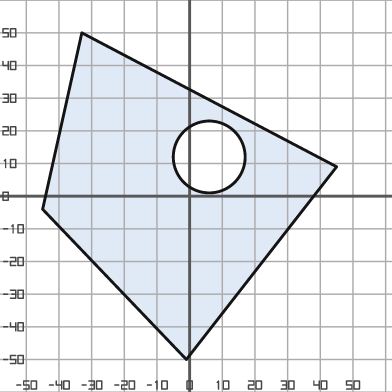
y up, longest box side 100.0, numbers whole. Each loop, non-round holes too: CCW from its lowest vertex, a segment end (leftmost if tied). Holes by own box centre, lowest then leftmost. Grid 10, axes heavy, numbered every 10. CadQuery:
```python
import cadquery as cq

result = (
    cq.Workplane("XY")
    .moveTo(-1.0, -50.0)
    .lineTo(45.0, 9.0)
    .lineTo(-33.0, 50.0)
    .lineTo(-45.0, -4.0)
    .close()
    .moveTo(6.0, 12.0)
    .circle(11.0)
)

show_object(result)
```